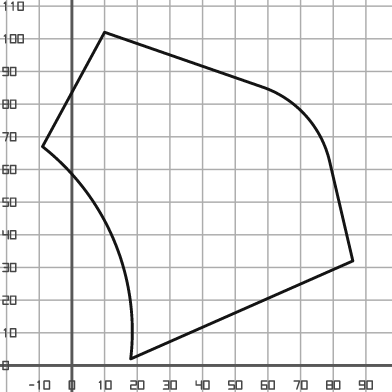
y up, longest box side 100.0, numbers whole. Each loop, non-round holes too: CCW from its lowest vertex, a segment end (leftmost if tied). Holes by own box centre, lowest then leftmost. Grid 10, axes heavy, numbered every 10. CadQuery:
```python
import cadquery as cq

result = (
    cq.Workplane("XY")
    .moveTo(18.0, 2.0)
    .lineTo(86.0, 32.0)
    .lineTo(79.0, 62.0)
    .threePointArc((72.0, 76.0), (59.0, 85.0))
    .lineTo(10.0, 102.0)
    .lineTo(-9.0, 67.0)
    .threePointArc((13.0, 38.0), (18.0, 2.0))
    .close()
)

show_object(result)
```